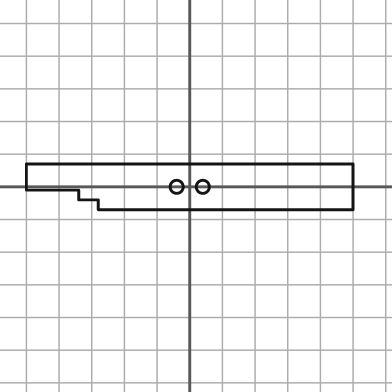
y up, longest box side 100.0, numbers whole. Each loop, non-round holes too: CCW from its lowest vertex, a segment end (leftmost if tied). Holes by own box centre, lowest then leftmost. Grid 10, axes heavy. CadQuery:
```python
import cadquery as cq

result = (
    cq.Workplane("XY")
    .moveTo(-28.0, -7.0)
    .lineTo(50.0, -7.0)
    .lineTo(50.0, 7.0)
    .lineTo(-50.0, 7.0)
    .lineTo(-50.0, -1.0)
    .lineTo(-34.0, -1.0)
    .lineTo(-34.0, -4.0)
    .lineTo(-28.0, -4.0)
    .close()
    .moveTo(-4.0, 0.0)
    .circle(2.0)
    .moveTo(4.0, 0.0)
    .circle(2.0)
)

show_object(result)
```